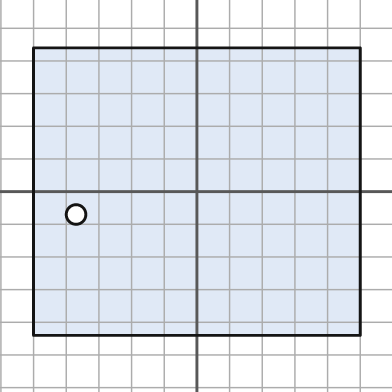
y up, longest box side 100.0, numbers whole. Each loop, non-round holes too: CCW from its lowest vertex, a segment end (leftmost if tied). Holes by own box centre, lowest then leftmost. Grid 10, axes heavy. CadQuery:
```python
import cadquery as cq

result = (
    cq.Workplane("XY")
    .moveTo(-50.0, -44.0)
    .lineTo(50.0, -44.0)
    .lineTo(50.0, 44.0)
    .lineTo(-50.0, 44.0)
    .close()
    .moveTo(-37.0, -7.0)
    .circle(3.0)
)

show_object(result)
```